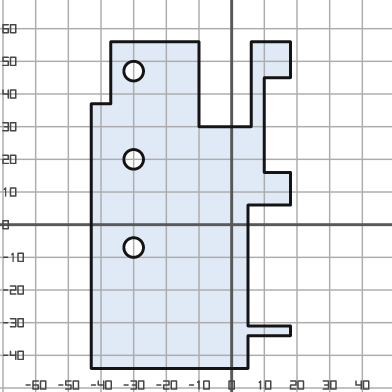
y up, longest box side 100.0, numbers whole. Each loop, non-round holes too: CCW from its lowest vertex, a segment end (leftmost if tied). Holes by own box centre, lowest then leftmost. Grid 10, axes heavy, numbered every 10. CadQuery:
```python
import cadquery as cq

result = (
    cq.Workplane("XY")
    .moveTo(-43.0, -44.0)
    .lineTo(5.0, -44.0)
    .lineTo(5.0, -34.0)
    .lineTo(18.0, -34.0)
    .lineTo(18.0, -31.0)
    .lineTo(5.0, -31.0)
    .lineTo(5.0, 6.0)
    .lineTo(18.0, 6.0)
    .lineTo(18.0, 16.0)
    .lineTo(10.0, 16.0)
    .lineTo(10.0, 45.0)
    .lineTo(18.0, 45.0)
    .lineTo(18.0, 56.0)
    .lineTo(6.0, 56.0)
    .lineTo(6.0, 30.0)
    .lineTo(-10.0, 30.0)
    .lineTo(-10.0, 56.0)
    .lineTo(-37.0, 56.0)
    .lineTo(-37.0, 37.0)
    .lineTo(-43.0, 37.0)
    .close()
    .moveTo(-30.0, -7.0)
    .circle(3.0)
    .moveTo(-30.0, 20.0)
    .circle(3.0)
    .moveTo(-30.0, 47.0)
    .circle(3.0)
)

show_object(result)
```